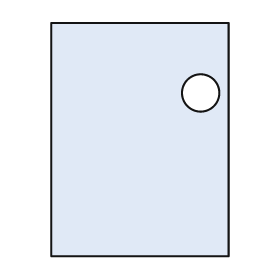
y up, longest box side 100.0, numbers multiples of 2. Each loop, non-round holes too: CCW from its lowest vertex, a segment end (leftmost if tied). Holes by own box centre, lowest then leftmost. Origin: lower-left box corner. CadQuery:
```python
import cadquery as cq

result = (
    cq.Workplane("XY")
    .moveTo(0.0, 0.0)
    .lineTo(76.0, 0.0)
    .lineTo(76.0, 100.0)
    .lineTo(0.0, 100.0)
    .close()
    .moveTo(64.0, 70.0)
    .circle(8.0)
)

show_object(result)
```